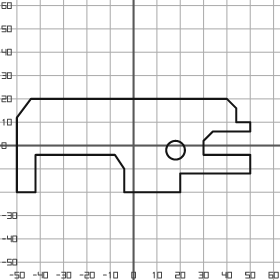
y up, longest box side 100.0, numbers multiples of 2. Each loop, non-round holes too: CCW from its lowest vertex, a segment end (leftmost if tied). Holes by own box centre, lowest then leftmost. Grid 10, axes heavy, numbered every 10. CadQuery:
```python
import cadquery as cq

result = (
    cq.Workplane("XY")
    .moveTo(-50.0, -20.0)
    .lineTo(-42.0, -20.0)
    .lineTo(-42.0, -4.0)
    .lineTo(-8.0, -4.0)
    .lineTo(-4.0, -10.0)
    .lineTo(-4.0, -20.0)
    .lineTo(20.0, -20.0)
    .lineTo(20.0, -12.0)
    .lineTo(50.0, -12.0)
    .lineTo(50.0, -4.0)
    .lineTo(30.0, -4.0)
    .lineTo(30.0, 2.0)
    .lineTo(34.0, 6.0)
    .lineTo(50.0, 6.0)
    .lineTo(50.0, 10.0)
    .lineTo(44.0, 10.0)
    .lineTo(44.0, 16.0)
    .lineTo(40.0, 20.0)
    .lineTo(-44.0, 20.0)
    .lineTo(-50.0, 12.0)
    .close()
    .moveTo(18.0, -2.0)
    .circle(4.0)
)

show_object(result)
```